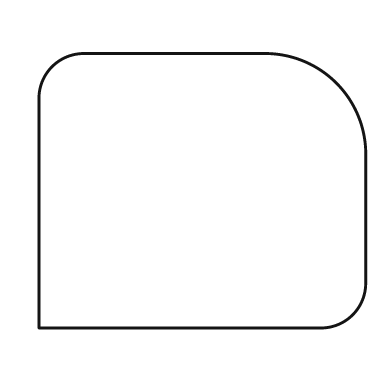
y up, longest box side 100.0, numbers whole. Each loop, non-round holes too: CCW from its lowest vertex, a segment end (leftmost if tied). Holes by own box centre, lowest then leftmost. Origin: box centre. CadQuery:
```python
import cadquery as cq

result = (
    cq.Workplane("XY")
    .moveTo(-50.0, -42.0)
    .lineTo(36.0, -42.0)
    .threePointArc((46.0, -38.0), (50.0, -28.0))
    .lineTo(50.0, 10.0)
    .threePointArc((41.0, 33.0), (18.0, 42.0))
    .lineTo(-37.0, 42.0)
    .threePointArc((-46.0, 38.0), (-50.0, 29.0))
    .close()
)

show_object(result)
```